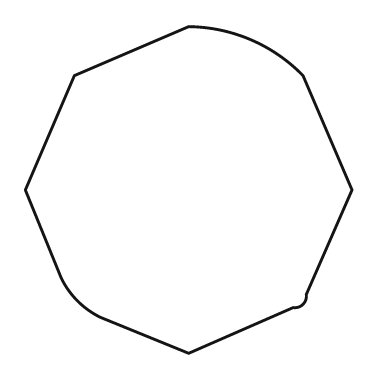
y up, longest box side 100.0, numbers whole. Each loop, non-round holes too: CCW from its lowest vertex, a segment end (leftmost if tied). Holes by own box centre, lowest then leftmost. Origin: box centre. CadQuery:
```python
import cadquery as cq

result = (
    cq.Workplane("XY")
    .moveTo(0.0, -50.0)
    .lineTo(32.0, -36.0)
    .threePointArc((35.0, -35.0), (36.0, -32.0))
    .lineTo(50.0, 0.0)
    .lineTo(35.0, 35.0)
    .threePointArc((19.0, 46.0), (0.0, 50.0))
    .lineTo(-35.0, 35.0)
    .lineTo(-50.0, 0.0)
    .lineTo(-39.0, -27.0)
    .threePointArc((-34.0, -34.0), (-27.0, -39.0))
    .close()
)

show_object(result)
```